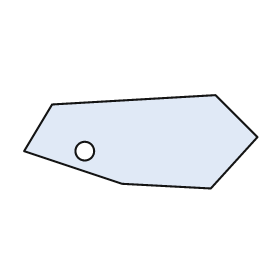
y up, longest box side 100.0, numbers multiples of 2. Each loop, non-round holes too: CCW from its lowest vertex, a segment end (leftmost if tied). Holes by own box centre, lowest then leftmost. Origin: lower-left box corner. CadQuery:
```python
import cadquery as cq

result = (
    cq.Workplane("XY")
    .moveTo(80.0, 0.0)
    .lineTo(100.0, 22.0)
    .lineTo(82.0, 40.0)
    .lineTo(12.0, 36.0)
    .lineTo(0.0, 16.0)
    .lineTo(42.0, 2.0)
    .close()
    .moveTo(26.0, 16.0)
    .circle(4.0)
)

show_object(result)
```